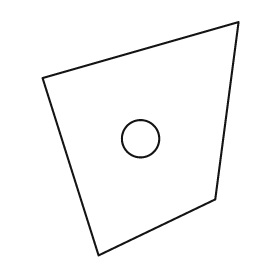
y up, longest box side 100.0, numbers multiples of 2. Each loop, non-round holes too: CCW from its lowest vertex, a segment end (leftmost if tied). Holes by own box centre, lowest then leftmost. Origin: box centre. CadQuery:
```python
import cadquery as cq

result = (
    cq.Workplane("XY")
    .moveTo(-18.0, -50.0)
    .lineTo(32.0, -26.0)
    .lineTo(42.0, 50.0)
    .lineTo(-42.0, 26.0)
    .close()
    .moveTo(0.0, 0.0)
    .circle(8.0)
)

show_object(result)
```